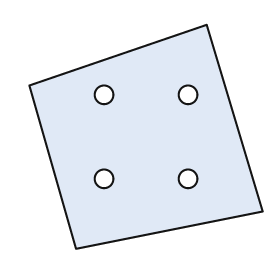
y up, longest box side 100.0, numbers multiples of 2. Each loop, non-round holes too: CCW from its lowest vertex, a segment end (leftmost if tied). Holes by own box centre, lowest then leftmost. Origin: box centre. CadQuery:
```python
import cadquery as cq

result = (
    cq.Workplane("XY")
    .moveTo(-30.0, -48.0)
    .lineTo(50.0, -32.0)
    .lineTo(26.0, 48.0)
    .lineTo(-50.0, 22.0)
    .close()
    .moveTo(-18.0, -18.0)
    .circle(4.0)
    .moveTo(18.0, -18.0)
    .circle(4.0)
    .moveTo(-18.0, 18.0)
    .circle(4.0)
    .moveTo(18.0, 18.0)
    .circle(4.0)
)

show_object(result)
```